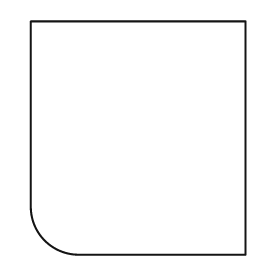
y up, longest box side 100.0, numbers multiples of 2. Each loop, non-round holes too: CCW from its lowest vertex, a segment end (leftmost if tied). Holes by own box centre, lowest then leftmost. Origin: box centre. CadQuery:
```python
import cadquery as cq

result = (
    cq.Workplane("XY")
    .moveTo(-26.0, -50.0)
    .lineTo(46.0, -50.0)
    .lineTo(46.0, 50.0)
    .lineTo(-46.0, 50.0)
    .lineTo(-46.0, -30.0)
    .threePointArc((-40.0, -44.0), (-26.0, -50.0))
    .close()
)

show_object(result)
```